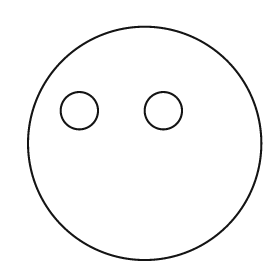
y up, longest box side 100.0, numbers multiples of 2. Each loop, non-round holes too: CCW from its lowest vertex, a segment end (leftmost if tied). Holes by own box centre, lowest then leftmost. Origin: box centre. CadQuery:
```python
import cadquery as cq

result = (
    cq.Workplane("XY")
    .moveTo(0.0, 0.0)
    .circle(50.0)
    .moveTo(-28.0, 14.0)
    .circle(8.0)
    .moveTo(8.0, 14.0)
    .circle(8.0)
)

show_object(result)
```